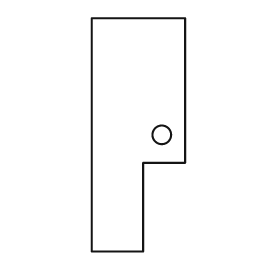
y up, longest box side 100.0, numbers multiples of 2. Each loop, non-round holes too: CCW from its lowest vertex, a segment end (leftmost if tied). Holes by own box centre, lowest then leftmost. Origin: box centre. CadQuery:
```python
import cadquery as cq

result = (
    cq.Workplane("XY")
    .moveTo(-20.0, -50.0)
    .lineTo(2.0, -50.0)
    .lineTo(2.0, -12.0)
    .lineTo(20.0, -12.0)
    .lineTo(20.0, 50.0)
    .lineTo(-20.0, 50.0)
    .close()
    .moveTo(10.0, 0.0)
    .circle(4.0)
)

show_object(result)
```